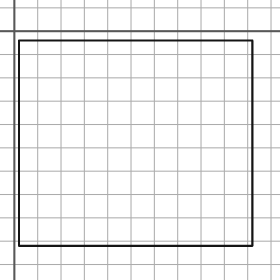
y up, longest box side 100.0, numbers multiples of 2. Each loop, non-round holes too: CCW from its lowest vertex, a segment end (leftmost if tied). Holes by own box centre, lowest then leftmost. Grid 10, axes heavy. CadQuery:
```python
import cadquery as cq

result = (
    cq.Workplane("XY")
    .moveTo(2.0, -92.0)
    .lineTo(102.0, -92.0)
    .lineTo(102.0, -4.0)
    .lineTo(2.0, -4.0)
    .close()
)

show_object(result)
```